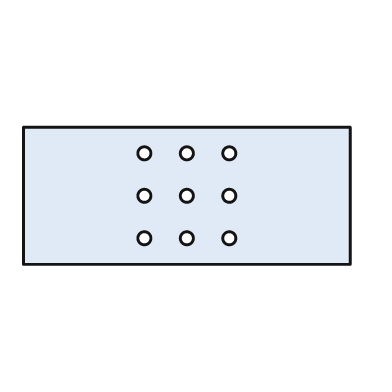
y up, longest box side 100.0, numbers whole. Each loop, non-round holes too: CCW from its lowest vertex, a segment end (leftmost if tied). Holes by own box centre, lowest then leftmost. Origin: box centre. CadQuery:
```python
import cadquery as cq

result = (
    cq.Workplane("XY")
    .moveTo(-50.0, -21.0)
    .lineTo(50.0, -21.0)
    .lineTo(50.0, 21.0)
    .lineTo(-50.0, 21.0)
    .close()
    .moveTo(-13.0, -13.0)
    .circle(2.0)
    .moveTo(0.0, -13.0)
    .circle(2.0)
    .moveTo(13.0, -13.0)
    .circle(2.0)
    .moveTo(-13.0, 0.0)
    .circle(2.0)
    .moveTo(0.0, 0.0)
    .circle(2.0)
    .moveTo(13.0, 0.0)
    .circle(2.0)
    .moveTo(-13.0, 13.0)
    .circle(2.0)
    .moveTo(0.0, 13.0)
    .circle(2.0)
    .moveTo(13.0, 13.0)
    .circle(2.0)
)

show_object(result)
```